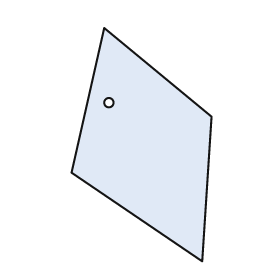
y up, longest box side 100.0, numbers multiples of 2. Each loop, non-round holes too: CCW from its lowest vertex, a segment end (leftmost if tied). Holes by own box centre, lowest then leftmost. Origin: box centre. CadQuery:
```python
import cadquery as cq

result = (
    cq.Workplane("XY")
    .moveTo(26.0, -50.0)
    .lineTo(30.0, 12.0)
    .lineTo(-16.0, 50.0)
    .lineTo(-30.0, -12.0)
    .close()
    .moveTo(-14.0, 18.0)
    .circle(2.0)
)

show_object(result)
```